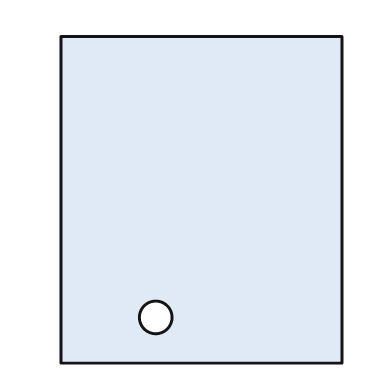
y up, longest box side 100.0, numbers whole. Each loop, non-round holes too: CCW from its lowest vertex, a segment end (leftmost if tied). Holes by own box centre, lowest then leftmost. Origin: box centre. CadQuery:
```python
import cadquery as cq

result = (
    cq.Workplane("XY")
    .moveTo(-43.0, -50.0)
    .lineTo(43.0, -50.0)
    .lineTo(43.0, 50.0)
    .lineTo(-43.0, 50.0)
    .close()
    .moveTo(-14.0, -36.0)
    .circle(5.0)
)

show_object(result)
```